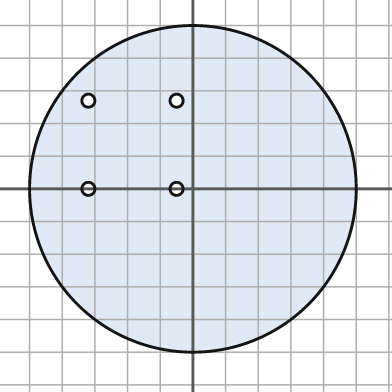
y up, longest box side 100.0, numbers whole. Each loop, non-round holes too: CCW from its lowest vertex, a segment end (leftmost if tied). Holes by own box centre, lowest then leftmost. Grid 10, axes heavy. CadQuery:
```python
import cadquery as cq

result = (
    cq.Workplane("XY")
    .moveTo(0.0, 0.0)
    .circle(50.0)
    .moveTo(-32.0, 0.0)
    .circle(2.0)
    .moveTo(-5.0, 0.0)
    .circle(2.0)
    .moveTo(-32.0, 27.0)
    .circle(2.0)
    .moveTo(-5.0, 27.0)
    .circle(2.0)
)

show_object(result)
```